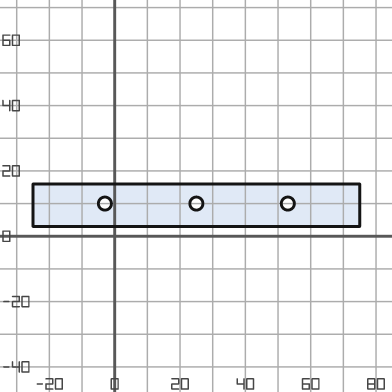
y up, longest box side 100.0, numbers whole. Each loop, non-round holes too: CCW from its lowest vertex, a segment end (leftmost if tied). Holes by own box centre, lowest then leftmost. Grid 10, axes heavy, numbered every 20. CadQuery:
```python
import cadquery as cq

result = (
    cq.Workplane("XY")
    .moveTo(-25.0, 3.0)
    .lineTo(75.0, 3.0)
    .lineTo(75.0, 16.0)
    .lineTo(-25.0, 16.0)
    .close()
    .moveTo(-3.0, 10.0)
    .circle(2.0)
    .moveTo(25.0, 10.0)
    .circle(2.0)
    .moveTo(53.0, 10.0)
    .circle(2.0)
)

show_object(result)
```